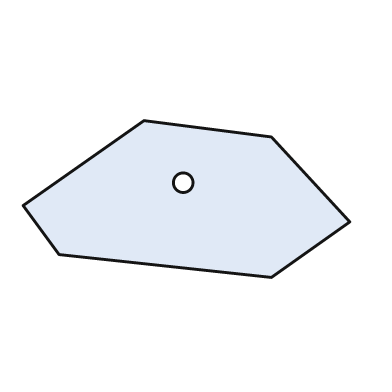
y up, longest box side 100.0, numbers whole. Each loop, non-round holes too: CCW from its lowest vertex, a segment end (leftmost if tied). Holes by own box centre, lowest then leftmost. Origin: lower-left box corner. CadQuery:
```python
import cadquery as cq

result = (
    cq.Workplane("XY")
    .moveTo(76.0, 0.0)
    .lineTo(100.0, 17.0)
    .lineTo(76.0, 43.0)
    .lineTo(37.0, 48.0)
    .lineTo(0.0, 22.0)
    .lineTo(11.0, 7.0)
    .close()
    .moveTo(49.0, 29.0)
    .circle(3.0)
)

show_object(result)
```